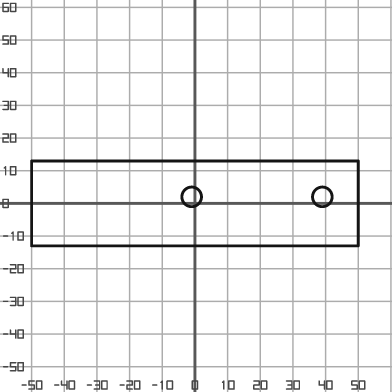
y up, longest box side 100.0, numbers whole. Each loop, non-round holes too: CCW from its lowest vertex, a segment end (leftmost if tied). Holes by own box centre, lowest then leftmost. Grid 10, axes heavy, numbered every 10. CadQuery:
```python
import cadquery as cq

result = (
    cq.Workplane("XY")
    .moveTo(-50.0, -13.0)
    .lineTo(50.0, -13.0)
    .lineTo(50.0, 13.0)
    .lineTo(-50.0, 13.0)
    .close()
    .moveTo(-1.0, 2.0)
    .circle(3.0)
    .moveTo(39.0, 2.0)
    .circle(3.0)
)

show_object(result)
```